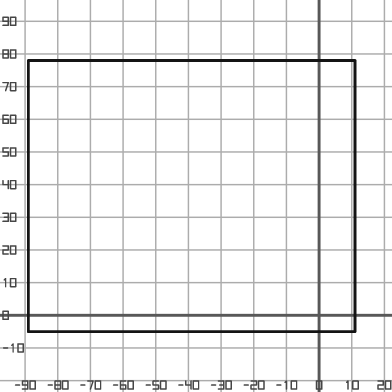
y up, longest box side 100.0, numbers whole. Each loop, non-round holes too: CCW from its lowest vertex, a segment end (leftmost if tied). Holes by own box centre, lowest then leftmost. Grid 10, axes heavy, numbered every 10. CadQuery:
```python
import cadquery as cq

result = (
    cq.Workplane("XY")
    .moveTo(-89.0, -5.0)
    .lineTo(11.0, -5.0)
    .lineTo(11.0, 78.0)
    .lineTo(-89.0, 78.0)
    .close()
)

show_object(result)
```